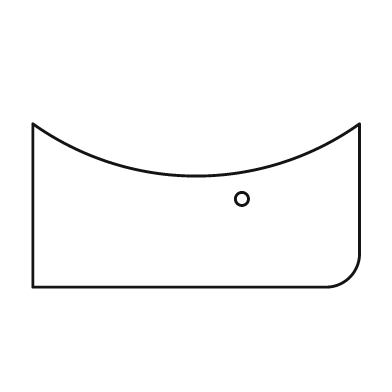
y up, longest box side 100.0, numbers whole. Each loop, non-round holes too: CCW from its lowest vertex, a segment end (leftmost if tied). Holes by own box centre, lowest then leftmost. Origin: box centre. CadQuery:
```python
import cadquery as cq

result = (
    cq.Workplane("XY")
    .moveTo(-50.0, -25.0)
    .lineTo(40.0, -25.0)
    .threePointArc((47.0, -22.0), (50.0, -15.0))
    .lineTo(50.0, 25.0)
    .threePointArc((0.0, 9.0), (-50.0, 25.0))
    .close()
    .moveTo(14.0, 2.0)
    .circle(2.0)
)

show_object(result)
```